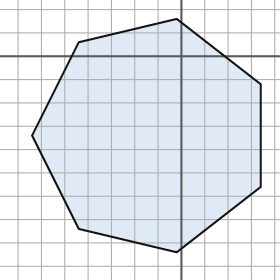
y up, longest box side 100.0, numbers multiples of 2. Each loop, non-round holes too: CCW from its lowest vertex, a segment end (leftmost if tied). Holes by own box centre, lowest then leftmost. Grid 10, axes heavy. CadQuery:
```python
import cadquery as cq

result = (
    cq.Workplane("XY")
    .moveTo(-2.0, -84.0)
    .lineTo(34.0, -56.0)
    .lineTo(34.0, -12.0)
    .lineTo(-2.0, 16.0)
    .lineTo(-44.0, 6.0)
    .lineTo(-64.0, -34.0)
    .lineTo(-44.0, -74.0)
    .close()
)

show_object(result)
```